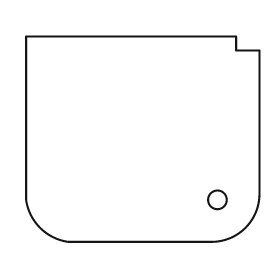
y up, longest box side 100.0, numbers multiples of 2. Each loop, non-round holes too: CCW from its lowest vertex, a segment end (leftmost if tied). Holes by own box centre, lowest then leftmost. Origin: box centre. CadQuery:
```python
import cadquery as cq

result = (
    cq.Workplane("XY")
    .moveTo(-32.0, -44.0)
    .lineTo(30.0, -44.0)
    .threePointArc((44.0, -38.0), (50.0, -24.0))
    .lineTo(50.0, 38.0)
    .lineTo(40.0, 38.0)
    .lineTo(40.0, 44.0)
    .lineTo(-50.0, 44.0)
    .lineTo(-50.0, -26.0)
    .threePointArc((-44.0, -38.0), (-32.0, -44.0))
    .close()
    .moveTo(32.0, -26.0)
    .circle(4.0)
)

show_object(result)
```